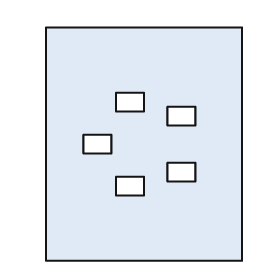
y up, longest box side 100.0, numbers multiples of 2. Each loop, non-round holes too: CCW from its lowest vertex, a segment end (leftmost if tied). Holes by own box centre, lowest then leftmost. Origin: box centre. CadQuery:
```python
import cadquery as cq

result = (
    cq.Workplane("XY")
    .moveTo(-42.0, -50.0)
    .lineTo(42.0, -50.0)
    .lineTo(42.0, 50.0)
    .lineTo(-42.0, 50.0)
    .close()
    .moveTo(-12.0, -22.0)
    .lineTo(0.0, -22.0)
    .lineTo(0.0, -14.0)
    .lineTo(-12.0, -14.0)
    .close()
    .moveTo(10.0, -16.0)
    .lineTo(22.0, -16.0)
    .lineTo(22.0, -8.0)
    .lineTo(10.0, -8.0)
    .close()
    .moveTo(-26.0, -4.0)
    .lineTo(-14.0, -4.0)
    .lineTo(-14.0, 4.0)
    .lineTo(-26.0, 4.0)
    .close()
    .moveTo(10.0, 8.0)
    .lineTo(22.0, 8.0)
    .lineTo(22.0, 16.0)
    .lineTo(10.0, 16.0)
    .close()
    .moveTo(-12.0, 14.0)
    .lineTo(0.0, 14.0)
    .lineTo(0.0, 22.0)
    .lineTo(-12.0, 22.0)
    .close()
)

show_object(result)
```